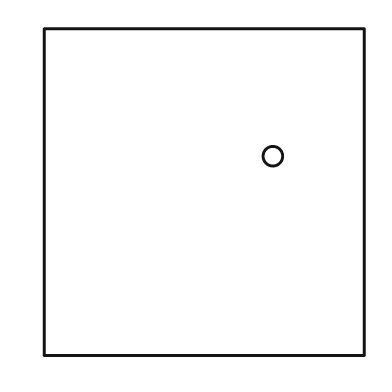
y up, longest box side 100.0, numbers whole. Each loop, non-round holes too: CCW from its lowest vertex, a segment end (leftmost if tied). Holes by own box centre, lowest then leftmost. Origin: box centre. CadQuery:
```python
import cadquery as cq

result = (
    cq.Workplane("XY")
    .moveTo(-49.0, -50.0)
    .lineTo(49.0, -50.0)
    .lineTo(49.0, 50.0)
    .lineTo(-49.0, 50.0)
    .close()
    .moveTo(21.0, 11.0)
    .circle(3.0)
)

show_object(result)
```